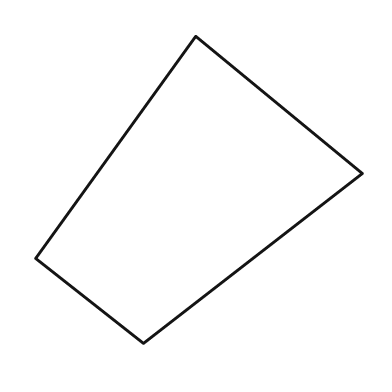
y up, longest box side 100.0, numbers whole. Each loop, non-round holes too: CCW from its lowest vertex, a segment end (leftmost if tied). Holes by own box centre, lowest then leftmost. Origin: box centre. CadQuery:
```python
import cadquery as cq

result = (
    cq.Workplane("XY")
    .moveTo(-17.0, -47.0)
    .lineTo(50.0, 5.0)
    .lineTo(-1.0, 47.0)
    .lineTo(-50.0, -21.0)
    .close()
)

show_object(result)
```